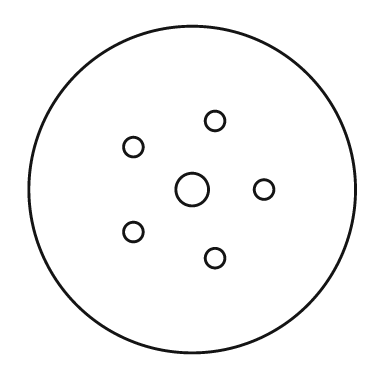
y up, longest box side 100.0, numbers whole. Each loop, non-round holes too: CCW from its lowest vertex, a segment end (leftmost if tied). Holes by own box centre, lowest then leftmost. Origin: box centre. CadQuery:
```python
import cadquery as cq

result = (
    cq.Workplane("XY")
    .moveTo(0.0, 0.0)
    .circle(50.0)
    .moveTo(7.0, -21.0)
    .circle(3.0)
    .moveTo(-18.0, -13.0)
    .circle(3.0)
    .moveTo(0.0, 0.0)
    .circle(5.0)
    .moveTo(22.0, 0.0)
    .circle(3.0)
    .moveTo(-18.0, 13.0)
    .circle(3.0)
    .moveTo(7.0, 21.0)
    .circle(3.0)
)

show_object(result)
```